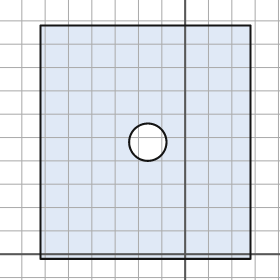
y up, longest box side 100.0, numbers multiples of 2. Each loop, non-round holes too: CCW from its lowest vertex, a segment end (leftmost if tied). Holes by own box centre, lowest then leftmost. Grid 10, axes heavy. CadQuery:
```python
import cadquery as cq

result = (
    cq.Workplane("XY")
    .moveTo(-62.0, -2.0)
    .lineTo(28.0, -2.0)
    .lineTo(28.0, 98.0)
    .lineTo(-62.0, 98.0)
    .close()
    .moveTo(-16.0, 48.0)
    .circle(8.0)
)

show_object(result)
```